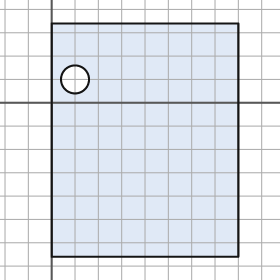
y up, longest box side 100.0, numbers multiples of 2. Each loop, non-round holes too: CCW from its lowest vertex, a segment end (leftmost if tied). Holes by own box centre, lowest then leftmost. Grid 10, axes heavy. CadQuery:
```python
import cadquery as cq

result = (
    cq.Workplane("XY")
    .moveTo(0.0, -66.0)
    .lineTo(80.0, -66.0)
    .lineTo(80.0, 34.0)
    .lineTo(0.0, 34.0)
    .close()
    .moveTo(10.0, 10.0)
    .circle(6.0)
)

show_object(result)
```